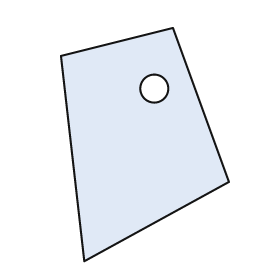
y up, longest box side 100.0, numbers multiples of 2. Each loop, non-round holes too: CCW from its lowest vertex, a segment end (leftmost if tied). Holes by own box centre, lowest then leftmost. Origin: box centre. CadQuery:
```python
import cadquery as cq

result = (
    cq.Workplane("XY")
    .moveTo(-26.0, -50.0)
    .lineTo(36.0, -16.0)
    .lineTo(12.0, 50.0)
    .lineTo(-36.0, 38.0)
    .close()
    .moveTo(4.0, 24.0)
    .circle(6.0)
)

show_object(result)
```